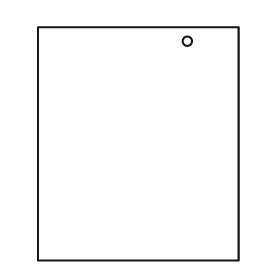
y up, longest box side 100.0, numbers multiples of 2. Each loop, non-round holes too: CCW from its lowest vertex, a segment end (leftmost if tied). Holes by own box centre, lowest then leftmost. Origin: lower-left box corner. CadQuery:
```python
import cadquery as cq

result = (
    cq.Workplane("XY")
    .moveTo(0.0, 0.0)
    .lineTo(86.0, 0.0)
    .lineTo(86.0, 100.0)
    .lineTo(0.0, 100.0)
    .close()
    .moveTo(64.0, 94.0)
    .circle(2.0)
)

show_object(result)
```